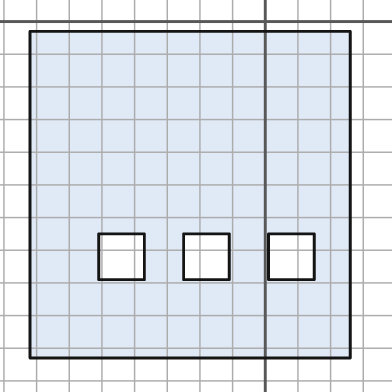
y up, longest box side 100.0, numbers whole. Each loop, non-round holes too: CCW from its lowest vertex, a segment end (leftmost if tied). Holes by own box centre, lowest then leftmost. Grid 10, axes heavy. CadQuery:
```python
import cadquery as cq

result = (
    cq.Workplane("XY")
    .moveTo(-72.0, -103.0)
    .lineTo(26.0, -103.0)
    .lineTo(26.0, -3.0)
    .lineTo(-72.0, -3.0)
    .close()
    .moveTo(-51.0, -79.0)
    .lineTo(-37.0, -79.0)
    .lineTo(-37.0, -65.0)
    .lineTo(-51.0, -65.0)
    .close()
    .moveTo(-25.0, -79.0)
    .lineTo(-11.0, -79.0)
    .lineTo(-11.0, -65.0)
    .lineTo(-25.0, -65.0)
    .close()
    .moveTo(1.0, -79.0)
    .lineTo(15.0, -79.0)
    .lineTo(15.0, -65.0)
    .lineTo(1.0, -65.0)
    .close()
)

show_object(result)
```